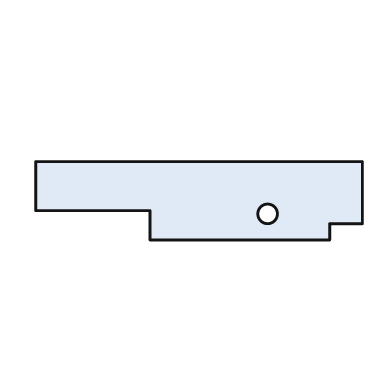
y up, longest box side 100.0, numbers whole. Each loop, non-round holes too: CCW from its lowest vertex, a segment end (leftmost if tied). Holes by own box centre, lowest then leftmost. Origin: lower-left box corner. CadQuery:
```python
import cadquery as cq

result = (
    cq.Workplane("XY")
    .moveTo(35.0, 0.0)
    .lineTo(90.0, 0.0)
    .lineTo(90.0, 5.0)
    .lineTo(100.0, 5.0)
    .lineTo(100.0, 24.0)
    .lineTo(0.0, 24.0)
    .lineTo(0.0, 9.0)
    .lineTo(35.0, 9.0)
    .close()
    .moveTo(71.0, 8.0)
    .circle(3.0)
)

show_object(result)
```